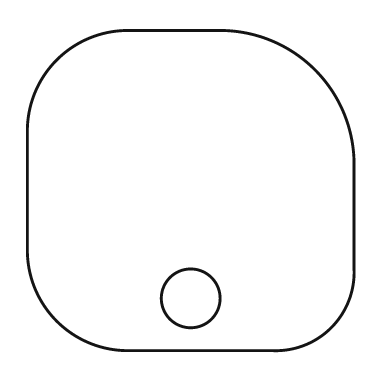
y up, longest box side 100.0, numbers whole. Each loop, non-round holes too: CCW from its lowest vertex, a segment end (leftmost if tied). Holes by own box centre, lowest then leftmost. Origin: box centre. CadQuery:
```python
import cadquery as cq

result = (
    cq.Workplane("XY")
    .moveTo(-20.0, -49.0)
    .lineTo(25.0, -49.0)
    .threePointArc((43.0, -42.0), (50.0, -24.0))
    .lineTo(50.0, 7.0)
    .threePointArc((38.0, 37.0), (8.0, 49.0))
    .lineTo(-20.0, 49.0)
    .threePointArc((-41.0, 40.0), (-50.0, 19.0))
    .lineTo(-50.0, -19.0)
    .threePointArc((-41.0, -40.0), (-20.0, -49.0))
    .close()
    .moveTo(0.0, -33.0)
    .circle(9.0)
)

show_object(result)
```